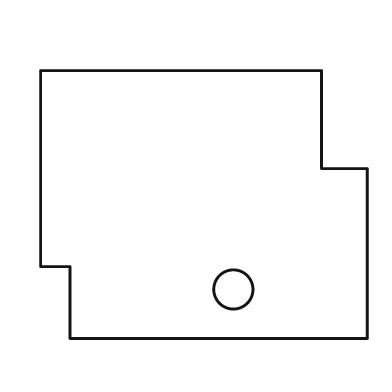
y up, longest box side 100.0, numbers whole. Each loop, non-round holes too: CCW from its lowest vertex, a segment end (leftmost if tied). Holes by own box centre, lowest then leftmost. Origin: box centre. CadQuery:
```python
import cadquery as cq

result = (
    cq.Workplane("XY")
    .moveTo(-41.0, -41.0)
    .lineTo(50.0, -41.0)
    .lineTo(50.0, 11.0)
    .lineTo(36.0, 11.0)
    .lineTo(36.0, 41.0)
    .lineTo(-50.0, 41.0)
    .lineTo(-50.0, -19.0)
    .lineTo(-41.0, -19.0)
    .close()
    .moveTo(9.0, -26.0)
    .circle(6.0)
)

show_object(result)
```